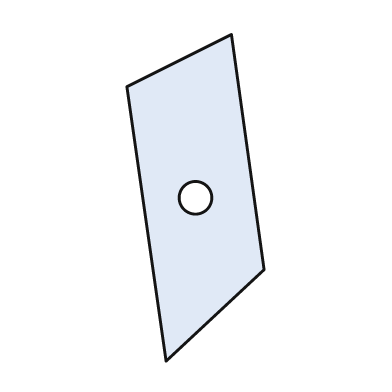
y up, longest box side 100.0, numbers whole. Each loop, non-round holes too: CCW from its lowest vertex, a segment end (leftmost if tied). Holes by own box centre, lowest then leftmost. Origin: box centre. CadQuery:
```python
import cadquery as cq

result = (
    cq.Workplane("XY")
    .moveTo(-9.0, -50.0)
    .lineTo(21.0, -22.0)
    .lineTo(11.0, 50.0)
    .lineTo(-21.0, 34.0)
    .close()
    .moveTo(0.0, 0.0)
    .circle(5.0)
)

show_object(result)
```